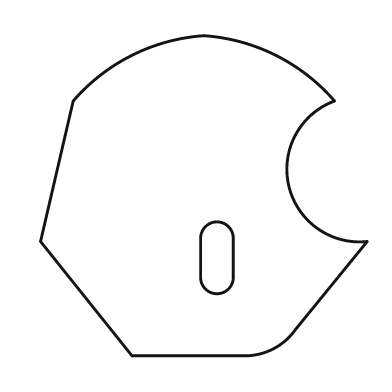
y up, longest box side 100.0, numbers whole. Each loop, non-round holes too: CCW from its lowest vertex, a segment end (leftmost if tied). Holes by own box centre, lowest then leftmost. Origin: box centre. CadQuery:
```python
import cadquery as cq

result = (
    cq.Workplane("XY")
    .moveTo(-22.0, -49.0)
    .lineTo(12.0, -49.0)
    .threePointArc((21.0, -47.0), (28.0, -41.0))
    .lineTo(50.0, -14.0)
    .threePointArc((26.0, 3.0), (40.0, 29.0))
    .threePointArc((22.0, 43.0), (0.0, 49.0))
    .threePointArc((-22.0, 43.0), (-40.0, 29.0))
    .lineTo(-50.0, -14.0)
    .close()
    .moveTo(-1.0, -25.0)
    .threePointArc((4.0, -30.0), (9.0, -25.0))
    .lineTo(9.0, -13.0)
    .threePointArc((4.0, -8.0), (-1.0, -13.0))
    .close()
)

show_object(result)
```